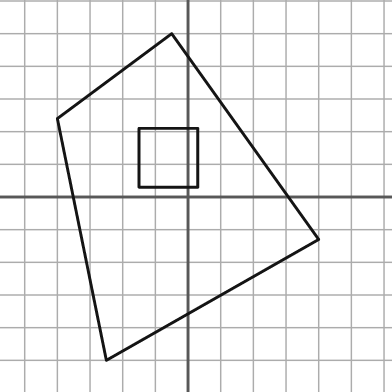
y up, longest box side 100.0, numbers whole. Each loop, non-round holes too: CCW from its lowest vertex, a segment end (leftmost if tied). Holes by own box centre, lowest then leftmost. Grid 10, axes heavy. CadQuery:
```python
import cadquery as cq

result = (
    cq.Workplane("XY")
    .moveTo(-25.0, -50.0)
    .lineTo(40.0, -13.0)
    .lineTo(-5.0, 50.0)
    .lineTo(-40.0, 24.0)
    .close()
    .moveTo(-15.0, 3.0)
    .lineTo(3.0, 3.0)
    .lineTo(3.0, 21.0)
    .lineTo(-15.0, 21.0)
    .close()
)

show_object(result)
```